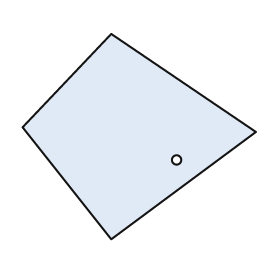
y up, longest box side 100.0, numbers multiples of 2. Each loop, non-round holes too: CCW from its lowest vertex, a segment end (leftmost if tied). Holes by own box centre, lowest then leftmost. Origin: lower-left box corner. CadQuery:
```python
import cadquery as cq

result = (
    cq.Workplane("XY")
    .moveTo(38.0, 0.0)
    .lineTo(100.0, 46.0)
    .lineTo(38.0, 88.0)
    .lineTo(0.0, 48.0)
    .close()
    .moveTo(66.0, 34.0)
    .circle(2.0)
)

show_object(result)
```